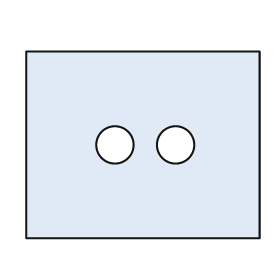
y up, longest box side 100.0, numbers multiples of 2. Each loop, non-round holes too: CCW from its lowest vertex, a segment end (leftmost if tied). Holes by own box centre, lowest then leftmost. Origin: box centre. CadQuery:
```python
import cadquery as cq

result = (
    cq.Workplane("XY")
    .moveTo(-50.0, -40.0)
    .lineTo(50.0, -40.0)
    .lineTo(50.0, 40.0)
    .lineTo(-50.0, 40.0)
    .close()
    .moveTo(-12.0, 0.0)
    .circle(8.0)
    .moveTo(14.0, 0.0)
    .circle(8.0)
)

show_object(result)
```